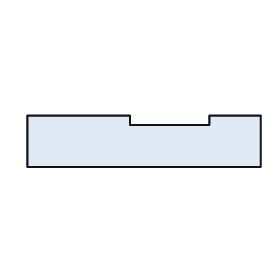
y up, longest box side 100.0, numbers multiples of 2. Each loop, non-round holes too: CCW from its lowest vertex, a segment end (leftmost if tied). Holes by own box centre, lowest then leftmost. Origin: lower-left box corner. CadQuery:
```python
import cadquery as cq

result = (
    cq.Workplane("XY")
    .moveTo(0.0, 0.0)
    .lineTo(100.0, 0.0)
    .lineTo(100.0, 22.0)
    .lineTo(78.0, 22.0)
    .lineTo(78.0, 18.0)
    .lineTo(44.0, 18.0)
    .lineTo(44.0, 22.0)
    .lineTo(0.0, 22.0)
    .close()
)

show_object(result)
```